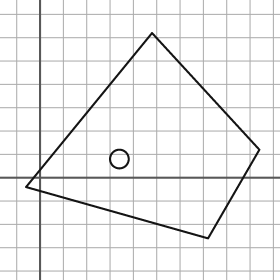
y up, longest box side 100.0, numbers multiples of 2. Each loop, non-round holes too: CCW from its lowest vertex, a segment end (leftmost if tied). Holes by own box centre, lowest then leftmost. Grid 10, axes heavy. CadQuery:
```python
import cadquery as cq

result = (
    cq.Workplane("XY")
    .moveTo(72.0, -26.0)
    .lineTo(94.0, 12.0)
    .lineTo(48.0, 62.0)
    .lineTo(-6.0, -4.0)
    .close()
    .moveTo(34.0, 8.0)
    .circle(4.0)
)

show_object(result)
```